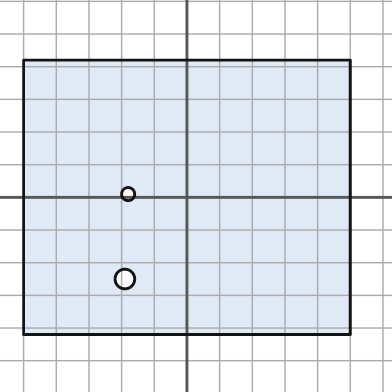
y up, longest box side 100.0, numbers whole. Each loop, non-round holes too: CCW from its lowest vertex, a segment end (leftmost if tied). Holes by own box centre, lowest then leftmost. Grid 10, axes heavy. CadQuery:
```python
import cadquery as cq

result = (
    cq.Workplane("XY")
    .moveTo(-50.0, -42.0)
    .lineTo(50.0, -42.0)
    .lineTo(50.0, 42.0)
    .lineTo(-50.0, 42.0)
    .close()
    .moveTo(-19.0, -25.0)
    .circle(3.0)
    .moveTo(-18.0, 1.0)
    .circle(2.0)
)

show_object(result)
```